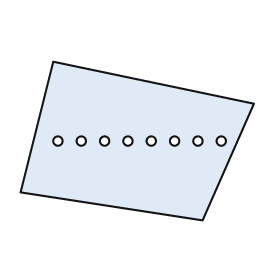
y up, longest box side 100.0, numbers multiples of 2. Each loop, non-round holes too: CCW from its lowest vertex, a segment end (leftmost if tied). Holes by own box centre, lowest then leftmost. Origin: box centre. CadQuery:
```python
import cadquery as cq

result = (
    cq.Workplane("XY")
    .moveTo(28.0, -34.0)
    .lineTo(50.0, 16.0)
    .lineTo(-36.0, 34.0)
    .lineTo(-50.0, -22.0)
    .close()
    .moveTo(-34.0, 0.0)
    .circle(2.0)
    .moveTo(-24.0, 0.0)
    .circle(2.0)
    .moveTo(-14.0, 0.0)
    .circle(2.0)
    .moveTo(-4.0, 0.0)
    .circle(2.0)
    .moveTo(6.0, 0.0)
    .circle(2.0)
    .moveTo(16.0, 0.0)
    .circle(2.0)
    .moveTo(26.0, 0.0)
    .circle(2.0)
    .moveTo(36.0, 0.0)
    .circle(2.0)
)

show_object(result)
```